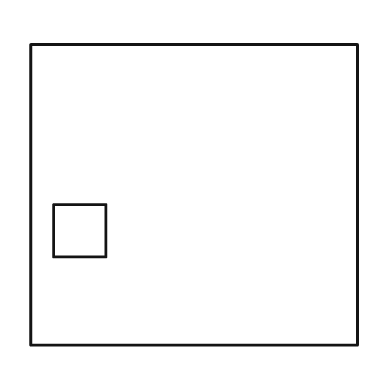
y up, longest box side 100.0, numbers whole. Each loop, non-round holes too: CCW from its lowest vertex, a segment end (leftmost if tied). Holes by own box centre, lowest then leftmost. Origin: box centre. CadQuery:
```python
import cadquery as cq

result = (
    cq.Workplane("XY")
    .moveTo(-50.0, -46.0)
    .lineTo(50.0, -46.0)
    .lineTo(50.0, 46.0)
    .lineTo(-50.0, 46.0)
    .close()
    .moveTo(-43.0, -19.0)
    .lineTo(-27.0, -19.0)
    .lineTo(-27.0, -3.0)
    .lineTo(-43.0, -3.0)
    .close()
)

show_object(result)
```